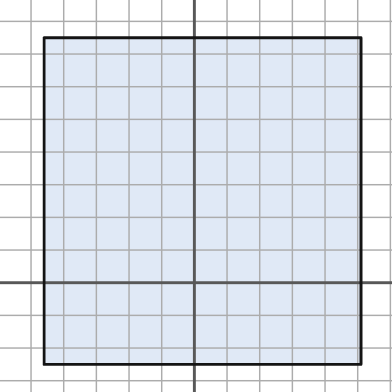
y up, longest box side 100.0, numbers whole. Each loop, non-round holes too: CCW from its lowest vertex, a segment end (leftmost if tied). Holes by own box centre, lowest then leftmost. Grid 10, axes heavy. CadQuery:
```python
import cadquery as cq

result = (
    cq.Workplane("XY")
    .moveTo(-46.0, -25.0)
    .lineTo(51.0, -25.0)
    .lineTo(51.0, 75.0)
    .lineTo(-46.0, 75.0)
    .close()
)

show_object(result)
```